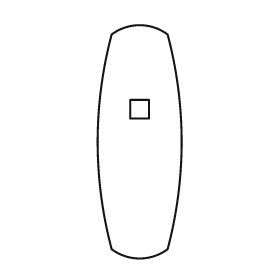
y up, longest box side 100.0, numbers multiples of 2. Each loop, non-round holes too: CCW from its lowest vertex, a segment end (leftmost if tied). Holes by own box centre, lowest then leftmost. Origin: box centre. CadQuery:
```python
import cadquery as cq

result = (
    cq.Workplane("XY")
    .moveTo(-12.0, -46.0)
    .threePointArc((0.0, -50.0), (12.0, -46.0))
    .threePointArc((18.0, 0.0), (12.0, 46.0))
    .threePointArc((0.0, 50.0), (-12.0, 46.0))
    .threePointArc((-18.0, 0.0), (-12.0, -46.0))
    .close()
    .moveTo(-4.0, 10.0)
    .lineTo(4.0, 10.0)
    .lineTo(4.0, 18.0)
    .lineTo(-4.0, 18.0)
    .close()
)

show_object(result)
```